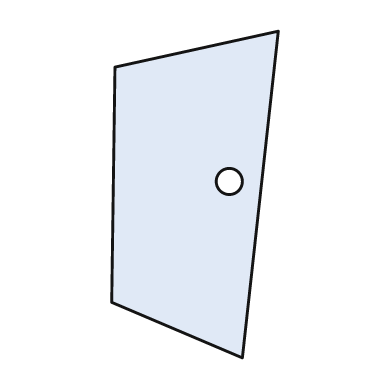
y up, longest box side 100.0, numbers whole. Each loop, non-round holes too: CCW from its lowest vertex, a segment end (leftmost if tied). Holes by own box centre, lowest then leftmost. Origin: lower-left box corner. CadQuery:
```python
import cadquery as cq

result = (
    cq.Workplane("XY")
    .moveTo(40.0, 0.0)
    .lineTo(51.0, 100.0)
    .lineTo(1.0, 89.0)
    .lineTo(0.0, 17.0)
    .close()
    .moveTo(36.0, 54.0)
    .circle(4.0)
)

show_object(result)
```